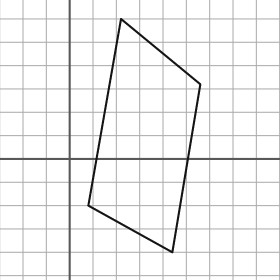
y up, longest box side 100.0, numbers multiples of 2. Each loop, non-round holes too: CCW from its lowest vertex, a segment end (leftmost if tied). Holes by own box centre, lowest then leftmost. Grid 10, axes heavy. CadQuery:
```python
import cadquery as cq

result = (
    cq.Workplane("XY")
    .moveTo(44.0, -40.0)
    .lineTo(56.0, 32.0)
    .lineTo(22.0, 60.0)
    .lineTo(8.0, -20.0)
    .close()
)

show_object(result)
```